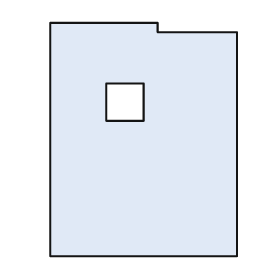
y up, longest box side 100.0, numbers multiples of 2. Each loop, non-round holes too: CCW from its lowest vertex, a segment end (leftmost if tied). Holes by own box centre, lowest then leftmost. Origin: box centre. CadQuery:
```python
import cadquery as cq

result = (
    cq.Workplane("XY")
    .moveTo(-40.0, -50.0)
    .lineTo(40.0, -50.0)
    .lineTo(40.0, 46.0)
    .lineTo(6.0, 46.0)
    .lineTo(6.0, 50.0)
    .lineTo(-40.0, 50.0)
    .close()
    .moveTo(-16.0, 8.0)
    .lineTo(0.0, 8.0)
    .lineTo(0.0, 24.0)
    .lineTo(-16.0, 24.0)
    .close()
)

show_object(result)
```